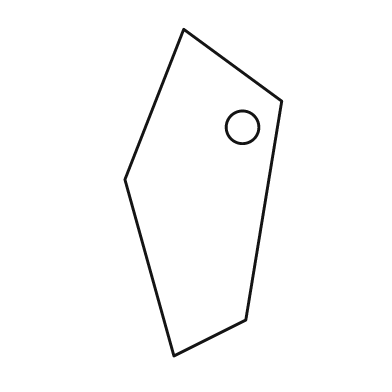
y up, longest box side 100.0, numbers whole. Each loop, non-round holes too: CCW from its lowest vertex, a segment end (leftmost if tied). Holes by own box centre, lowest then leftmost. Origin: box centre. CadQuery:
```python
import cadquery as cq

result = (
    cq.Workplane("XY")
    .moveTo(-9.0, -50.0)
    .lineTo(13.0, -39.0)
    .lineTo(24.0, 28.0)
    .lineTo(-6.0, 50.0)
    .lineTo(-24.0, 4.0)
    .close()
    .moveTo(12.0, 20.0)
    .circle(5.0)
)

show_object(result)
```